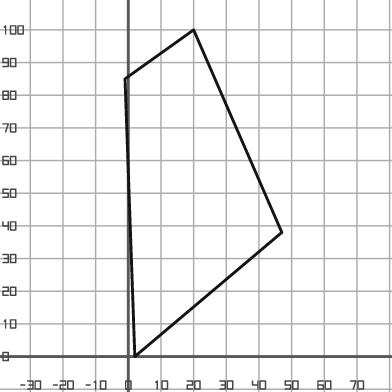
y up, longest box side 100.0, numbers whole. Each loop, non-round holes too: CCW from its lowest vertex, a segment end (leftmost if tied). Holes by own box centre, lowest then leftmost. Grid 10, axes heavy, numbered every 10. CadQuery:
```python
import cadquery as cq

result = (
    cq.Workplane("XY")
    .moveTo(2.0, 0.0)
    .lineTo(47.0, 38.0)
    .lineTo(20.0, 100.0)
    .lineTo(-1.0, 85.0)
    .close()
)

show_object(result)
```